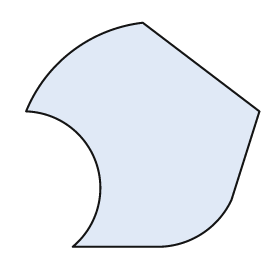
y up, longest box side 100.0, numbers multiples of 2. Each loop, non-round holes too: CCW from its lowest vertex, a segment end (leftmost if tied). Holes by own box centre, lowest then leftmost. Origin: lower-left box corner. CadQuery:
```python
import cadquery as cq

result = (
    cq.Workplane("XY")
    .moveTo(20.0, 0.0)
    .lineTo(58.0, 0.0)
    .threePointArc((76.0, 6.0), (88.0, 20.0))
    .lineTo(100.0, 58.0)
    .lineTo(50.0, 96.0)
    .threePointArc((20.0, 84.0), (0.0, 58.0))
    .threePointArc((30.0, 36.0), (20.0, 0.0))
    .close()
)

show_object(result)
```